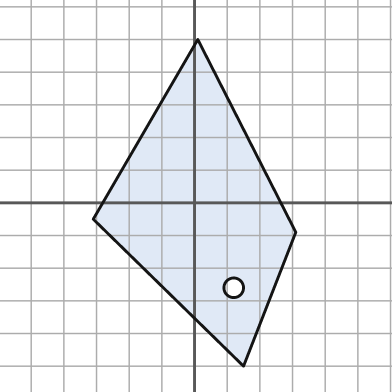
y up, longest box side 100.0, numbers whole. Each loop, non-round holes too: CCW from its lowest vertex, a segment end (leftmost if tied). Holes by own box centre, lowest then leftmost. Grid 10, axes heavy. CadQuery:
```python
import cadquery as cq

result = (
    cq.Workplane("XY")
    .moveTo(15.0, -50.0)
    .lineTo(31.0, -9.0)
    .lineTo(1.0, 50.0)
    .lineTo(-31.0, -5.0)
    .close()
    .moveTo(12.0, -26.0)
    .circle(3.0)
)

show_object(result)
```